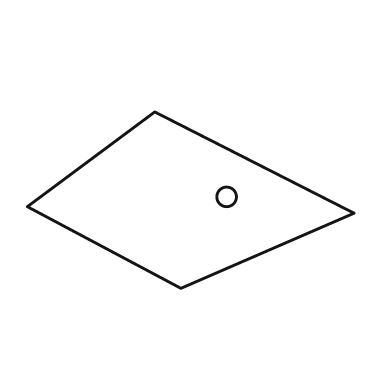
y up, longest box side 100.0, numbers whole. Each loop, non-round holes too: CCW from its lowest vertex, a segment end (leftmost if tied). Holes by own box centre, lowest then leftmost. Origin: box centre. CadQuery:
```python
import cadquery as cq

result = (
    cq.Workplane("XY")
    .moveTo(-3.0, -27.0)
    .lineTo(50.0, -4.0)
    .lineTo(-11.0, 27.0)
    .lineTo(-50.0, -2.0)
    .close()
    .moveTo(11.0, 1.0)
    .circle(3.0)
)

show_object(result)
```